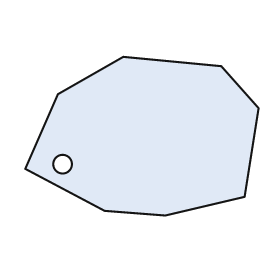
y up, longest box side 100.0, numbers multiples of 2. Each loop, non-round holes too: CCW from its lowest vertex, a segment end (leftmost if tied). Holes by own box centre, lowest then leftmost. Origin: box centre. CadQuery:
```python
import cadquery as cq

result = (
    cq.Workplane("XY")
    .moveTo(10.0, -34.0)
    .lineTo(44.0, -26.0)
    .lineTo(50.0, 12.0)
    .lineTo(34.0, 30.0)
    .lineTo(-8.0, 34.0)
    .lineTo(-36.0, 18.0)
    .lineTo(-50.0, -14.0)
    .lineTo(-16.0, -32.0)
    .close()
    .moveTo(-34.0, -12.0)
    .circle(4.0)
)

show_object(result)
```